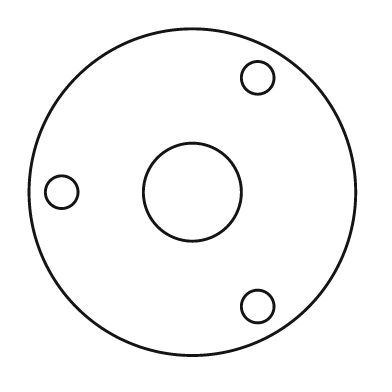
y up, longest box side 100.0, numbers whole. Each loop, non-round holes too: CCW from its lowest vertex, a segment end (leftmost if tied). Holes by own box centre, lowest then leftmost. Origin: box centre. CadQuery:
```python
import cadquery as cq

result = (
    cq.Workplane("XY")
    .moveTo(0.0, 0.0)
    .circle(50.0)
    .moveTo(20.0, -35.0)
    .circle(5.0)
    .moveTo(-40.0, 0.0)
    .circle(5.0)
    .moveTo(0.0, 0.0)
    .circle(15.0)
    .moveTo(20.0, 35.0)
    .circle(5.0)
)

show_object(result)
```